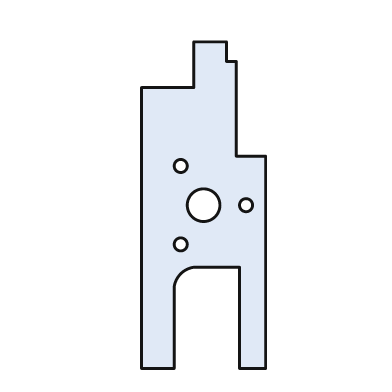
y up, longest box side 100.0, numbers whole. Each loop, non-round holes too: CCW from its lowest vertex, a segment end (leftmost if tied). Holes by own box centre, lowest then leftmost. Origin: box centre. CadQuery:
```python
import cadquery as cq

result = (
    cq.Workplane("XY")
    .moveTo(-19.0, -50.0)
    .lineTo(-9.0, -50.0)
    .lineTo(-9.0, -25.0)
    .threePointArc((-7.0, -21.0), (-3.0, -19.0))
    .lineTo(11.0, -19.0)
    .lineTo(11.0, -50.0)
    .lineTo(19.0, -50.0)
    .lineTo(19.0, 15.0)
    .lineTo(10.0, 15.0)
    .lineTo(10.0, 44.0)
    .lineTo(7.0, 44.0)
    .lineTo(7.0, 50.0)
    .lineTo(-3.0, 50.0)
    .lineTo(-3.0, 36.0)
    .lineTo(-19.0, 36.0)
    .close()
    .moveTo(-7.0, -12.0)
    .circle(2.0)
    .moveTo(0.0, 0.0)
    .circle(5.0)
    .moveTo(13.0, 0.0)
    .circle(2.0)
    .moveTo(-7.0, 12.0)
    .circle(2.0)
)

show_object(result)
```